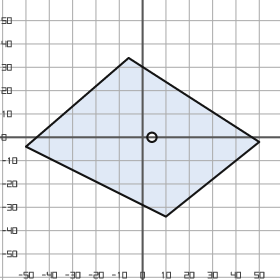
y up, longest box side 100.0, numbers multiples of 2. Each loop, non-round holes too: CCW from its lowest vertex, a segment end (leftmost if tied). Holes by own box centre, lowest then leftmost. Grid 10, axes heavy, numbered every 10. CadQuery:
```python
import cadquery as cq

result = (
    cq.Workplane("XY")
    .moveTo(10.0, -34.0)
    .lineTo(50.0, -2.0)
    .lineTo(-6.0, 34.0)
    .lineTo(-50.0, -4.0)
    .close()
    .moveTo(4.0, 0.0)
    .circle(2.0)
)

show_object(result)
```